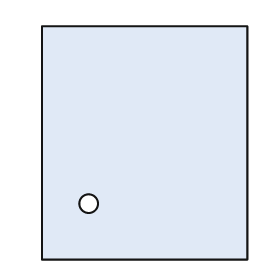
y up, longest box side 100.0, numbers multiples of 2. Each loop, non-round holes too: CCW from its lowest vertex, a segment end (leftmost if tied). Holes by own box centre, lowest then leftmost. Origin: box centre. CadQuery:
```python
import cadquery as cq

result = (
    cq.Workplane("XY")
    .moveTo(-44.0, -50.0)
    .lineTo(44.0, -50.0)
    .lineTo(44.0, 50.0)
    .lineTo(-44.0, 50.0)
    .close()
    .moveTo(-24.0, -26.0)
    .circle(4.0)
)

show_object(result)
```